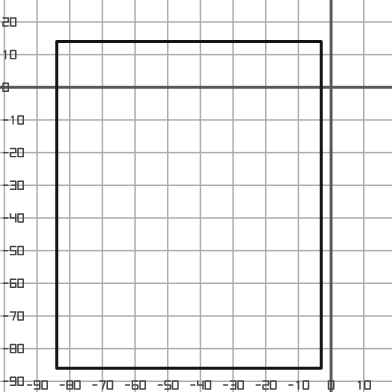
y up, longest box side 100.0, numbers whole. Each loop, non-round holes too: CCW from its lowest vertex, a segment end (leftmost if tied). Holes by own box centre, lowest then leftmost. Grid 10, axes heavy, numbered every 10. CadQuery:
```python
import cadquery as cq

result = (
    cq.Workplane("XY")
    .moveTo(-84.0, -86.0)
    .lineTo(-3.0, -86.0)
    .lineTo(-3.0, 14.0)
    .lineTo(-84.0, 14.0)
    .close()
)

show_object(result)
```